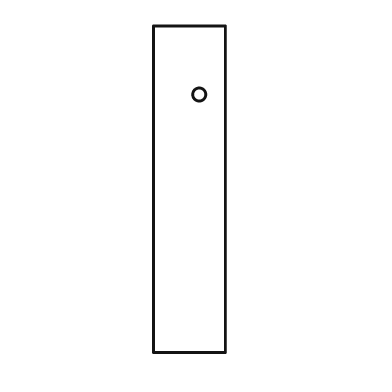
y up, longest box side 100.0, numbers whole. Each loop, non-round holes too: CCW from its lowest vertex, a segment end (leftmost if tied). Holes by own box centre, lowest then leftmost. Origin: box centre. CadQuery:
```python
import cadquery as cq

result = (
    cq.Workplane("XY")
    .moveTo(-11.0, -50.0)
    .lineTo(11.0, -50.0)
    .lineTo(11.0, 50.0)
    .lineTo(-11.0, 50.0)
    .close()
    .moveTo(3.0, 29.0)
    .circle(2.0)
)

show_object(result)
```